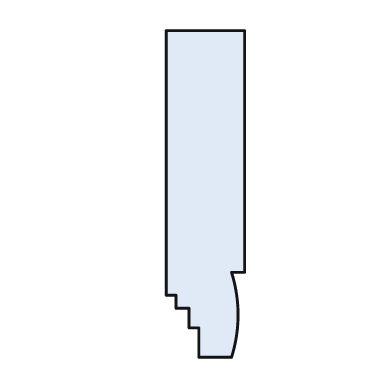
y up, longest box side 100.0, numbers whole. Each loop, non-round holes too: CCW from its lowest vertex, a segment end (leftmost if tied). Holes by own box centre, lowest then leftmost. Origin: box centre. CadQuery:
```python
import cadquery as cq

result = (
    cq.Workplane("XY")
    .moveTo(-2.0, -50.0)
    .lineTo(8.0, -50.0)
    .threePointArc((10.0, -37.0), (8.0, -24.0))
    .lineTo(12.0, -24.0)
    .lineTo(12.0, 50.0)
    .lineTo(-12.0, 50.0)
    .lineTo(-12.0, -31.0)
    .lineTo(-9.0, -31.0)
    .lineTo(-9.0, -35.0)
    .lineTo(-5.0, -35.0)
    .lineTo(-5.0, -41.0)
    .lineTo(-2.0, -41.0)
    .close()
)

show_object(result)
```